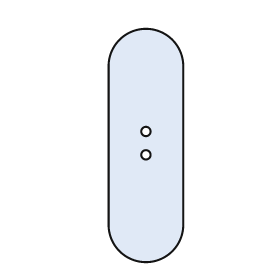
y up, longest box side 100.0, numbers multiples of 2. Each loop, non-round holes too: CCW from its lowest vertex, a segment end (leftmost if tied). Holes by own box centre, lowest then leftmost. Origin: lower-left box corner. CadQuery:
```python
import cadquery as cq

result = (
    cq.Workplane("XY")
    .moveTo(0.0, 16.0)
    .threePointArc((16.0, 0.0), (32.0, 16.0))
    .lineTo(32.0, 84.0)
    .threePointArc((16.0, 100.0), (0.0, 84.0))
    .close()
    .moveTo(16.0, 46.0)
    .circle(2.0)
    .moveTo(16.0, 56.0)
    .circle(2.0)
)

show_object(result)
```